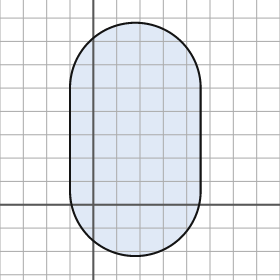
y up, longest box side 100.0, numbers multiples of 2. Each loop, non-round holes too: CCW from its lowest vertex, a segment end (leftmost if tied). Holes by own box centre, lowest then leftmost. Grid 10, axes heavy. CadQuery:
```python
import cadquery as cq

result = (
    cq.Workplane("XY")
    .moveTo(-10.0, 6.0)
    .threePointArc((18.0, -22.0), (46.0, 6.0))
    .lineTo(46.0, 50.0)
    .threePointArc((18.0, 78.0), (-10.0, 50.0))
    .close()
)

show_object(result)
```